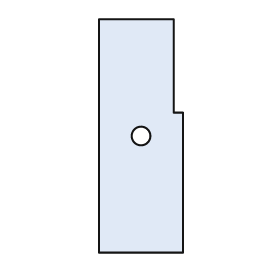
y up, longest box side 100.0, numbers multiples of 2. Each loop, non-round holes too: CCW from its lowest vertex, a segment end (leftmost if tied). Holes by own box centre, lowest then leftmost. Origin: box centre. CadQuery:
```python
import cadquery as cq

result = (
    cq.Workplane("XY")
    .moveTo(-18.0, -50.0)
    .lineTo(18.0, -50.0)
    .lineTo(18.0, 10.0)
    .lineTo(14.0, 10.0)
    .lineTo(14.0, 50.0)
    .lineTo(-18.0, 50.0)
    .close()
    .moveTo(0.0, 0.0)
    .circle(4.0)
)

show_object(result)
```